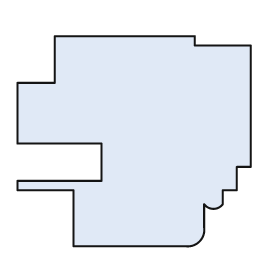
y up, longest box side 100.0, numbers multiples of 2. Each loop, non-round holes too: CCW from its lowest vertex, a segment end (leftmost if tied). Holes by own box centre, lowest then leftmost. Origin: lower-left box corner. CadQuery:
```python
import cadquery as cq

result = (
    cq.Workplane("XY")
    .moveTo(24.0, 0.0)
    .lineTo(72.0, 0.0)
    .threePointArc((78.0, 2.0), (80.0, 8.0))
    .lineTo(80.0, 18.0)
    .threePointArc((84.0, 16.0), (88.0, 18.0))
    .lineTo(88.0, 24.0)
    .lineTo(94.0, 24.0)
    .lineTo(94.0, 34.0)
    .lineTo(100.0, 34.0)
    .lineTo(100.0, 86.0)
    .lineTo(76.0, 86.0)
    .lineTo(76.0, 90.0)
    .lineTo(16.0, 90.0)
    .lineTo(16.0, 70.0)
    .lineTo(0.0, 70.0)
    .lineTo(0.0, 44.0)
    .lineTo(36.0, 44.0)
    .lineTo(36.0, 28.0)
    .lineTo(0.0, 28.0)
    .lineTo(0.0, 24.0)
    .lineTo(24.0, 24.0)
    .close()
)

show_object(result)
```